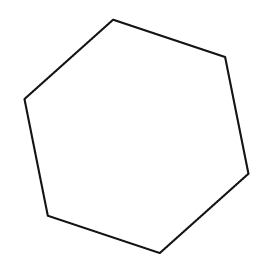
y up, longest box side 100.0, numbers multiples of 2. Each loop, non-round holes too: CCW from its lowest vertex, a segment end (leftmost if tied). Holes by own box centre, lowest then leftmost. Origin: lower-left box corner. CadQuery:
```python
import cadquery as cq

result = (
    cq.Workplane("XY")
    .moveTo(58.0, 0.0)
    .lineTo(96.0, 34.0)
    .lineTo(86.0, 84.0)
    .lineTo(38.0, 100.0)
    .lineTo(0.0, 66.0)
    .lineTo(10.0, 16.0)
    .close()
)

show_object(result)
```